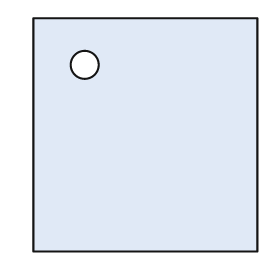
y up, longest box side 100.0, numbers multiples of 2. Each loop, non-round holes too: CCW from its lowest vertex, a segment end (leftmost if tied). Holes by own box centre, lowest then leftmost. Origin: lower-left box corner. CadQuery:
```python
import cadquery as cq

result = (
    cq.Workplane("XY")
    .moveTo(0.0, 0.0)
    .lineTo(96.0, 0.0)
    .lineTo(96.0, 100.0)
    .lineTo(0.0, 100.0)
    .close()
    .moveTo(22.0, 80.0)
    .circle(6.0)
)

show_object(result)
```